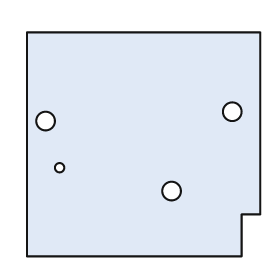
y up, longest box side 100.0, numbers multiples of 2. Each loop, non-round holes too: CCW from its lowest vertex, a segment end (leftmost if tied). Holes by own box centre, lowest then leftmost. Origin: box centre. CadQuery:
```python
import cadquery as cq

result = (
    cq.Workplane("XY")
    .moveTo(-50.0, -48.0)
    .lineTo(42.0, -48.0)
    .lineTo(42.0, -30.0)
    .lineTo(50.0, -30.0)
    .lineTo(50.0, 48.0)
    .lineTo(-50.0, 48.0)
    .close()
    .moveTo(12.0, -20.0)
    .circle(4.0)
    .moveTo(-36.0, -10.0)
    .circle(2.0)
    .moveTo(-42.0, 10.0)
    .circle(4.0)
    .moveTo(38.0, 14.0)
    .circle(4.0)
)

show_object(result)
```